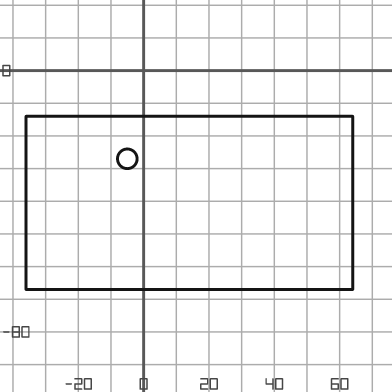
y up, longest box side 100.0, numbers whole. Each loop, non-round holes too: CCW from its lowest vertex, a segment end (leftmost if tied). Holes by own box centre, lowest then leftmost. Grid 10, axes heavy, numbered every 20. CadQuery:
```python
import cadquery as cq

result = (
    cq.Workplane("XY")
    .moveTo(-36.0, -67.0)
    .lineTo(64.0, -67.0)
    .lineTo(64.0, -14.0)
    .lineTo(-36.0, -14.0)
    .close()
    .moveTo(-5.0, -27.0)
    .circle(3.0)
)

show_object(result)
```